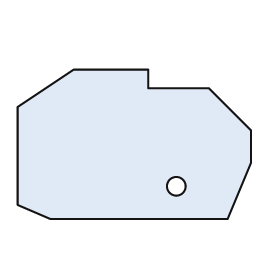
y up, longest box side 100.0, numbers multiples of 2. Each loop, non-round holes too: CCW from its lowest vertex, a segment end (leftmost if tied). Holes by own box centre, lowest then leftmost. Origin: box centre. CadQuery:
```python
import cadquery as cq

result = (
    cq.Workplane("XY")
    .moveTo(-36.0, -32.0)
    .lineTo(40.0, -32.0)
    .lineTo(50.0, -8.0)
    .lineTo(50.0, 6.0)
    .lineTo(32.0, 24.0)
    .lineTo(6.0, 24.0)
    .lineTo(6.0, 32.0)
    .lineTo(-26.0, 32.0)
    .lineTo(-50.0, 16.0)
    .lineTo(-50.0, -26.0)
    .close()
    .moveTo(18.0, -18.0)
    .circle(4.0)
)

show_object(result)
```